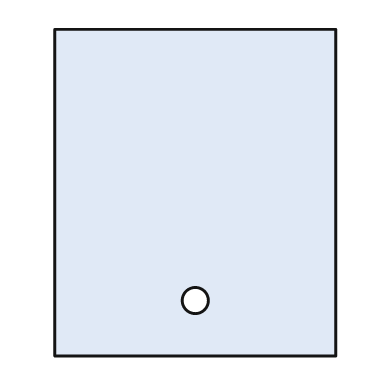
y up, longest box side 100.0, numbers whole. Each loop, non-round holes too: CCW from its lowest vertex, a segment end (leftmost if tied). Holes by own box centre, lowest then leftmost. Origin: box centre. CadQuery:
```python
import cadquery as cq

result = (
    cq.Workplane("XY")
    .moveTo(-43.0, -50.0)
    .lineTo(43.0, -50.0)
    .lineTo(43.0, 50.0)
    .lineTo(-43.0, 50.0)
    .close()
    .moveTo(0.0, -33.0)
    .circle(4.0)
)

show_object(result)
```